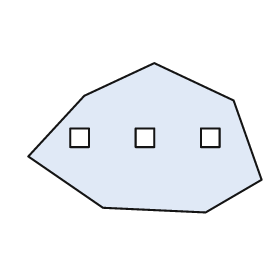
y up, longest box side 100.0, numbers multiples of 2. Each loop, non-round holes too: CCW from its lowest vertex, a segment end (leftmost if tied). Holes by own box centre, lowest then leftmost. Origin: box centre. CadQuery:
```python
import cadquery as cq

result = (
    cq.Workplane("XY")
    .moveTo(26.0, -32.0)
    .lineTo(50.0, -18.0)
    .lineTo(38.0, 16.0)
    .lineTo(4.0, 32.0)
    .lineTo(-26.0, 18.0)
    .lineTo(-50.0, -8.0)
    .lineTo(-18.0, -30.0)
    .close()
    .moveTo(-32.0, -4.0)
    .lineTo(-24.0, -4.0)
    .lineTo(-24.0, 4.0)
    .lineTo(-32.0, 4.0)
    .close()
    .moveTo(-4.0, -4.0)
    .lineTo(4.0, -4.0)
    .lineTo(4.0, 4.0)
    .lineTo(-4.0, 4.0)
    .close()
    .moveTo(24.0, -4.0)
    .lineTo(32.0, -4.0)
    .lineTo(32.0, 4.0)
    .lineTo(24.0, 4.0)
    .close()
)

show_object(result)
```